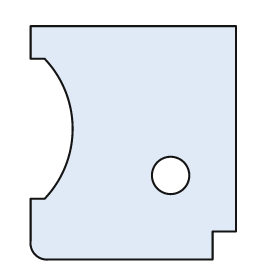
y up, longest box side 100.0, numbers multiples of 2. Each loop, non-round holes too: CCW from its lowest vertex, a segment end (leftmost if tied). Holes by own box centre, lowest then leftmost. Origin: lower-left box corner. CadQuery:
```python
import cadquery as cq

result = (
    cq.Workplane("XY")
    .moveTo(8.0, 0.0)
    .lineTo(78.0, 0.0)
    .lineTo(78.0, 12.0)
    .lineTo(88.0, 12.0)
    .lineTo(88.0, 100.0)
    .lineTo(0.0, 100.0)
    .lineTo(0.0, 86.0)
    .lineTo(6.0, 86.0)
    .threePointArc((18.0, 56.0), (6.0, 26.0))
    .lineTo(0.0, 26.0)
    .lineTo(0.0, 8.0)
    .threePointArc((2.0, 2.0), (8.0, 0.0))
    .close()
    .moveTo(60.0, 36.0)
    .circle(8.0)
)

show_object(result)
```